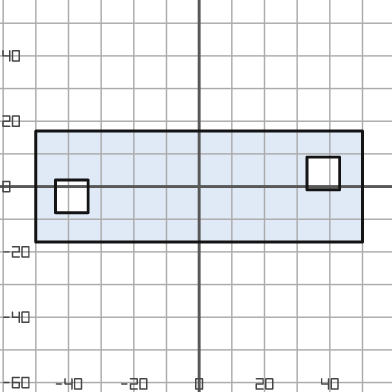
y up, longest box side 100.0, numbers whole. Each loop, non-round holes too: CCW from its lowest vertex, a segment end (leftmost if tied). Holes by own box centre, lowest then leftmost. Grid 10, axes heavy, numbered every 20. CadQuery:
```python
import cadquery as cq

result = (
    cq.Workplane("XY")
    .moveTo(-50.0, -17.0)
    .lineTo(50.0, -17.0)
    .lineTo(50.0, 17.0)
    .lineTo(-50.0, 17.0)
    .close()
    .moveTo(-44.0, -8.0)
    .lineTo(-34.0, -8.0)
    .lineTo(-34.0, 2.0)
    .lineTo(-44.0, 2.0)
    .close()
    .moveTo(33.0, -1.0)
    .lineTo(43.0, -1.0)
    .lineTo(43.0, 9.0)
    .lineTo(33.0, 9.0)
    .close()
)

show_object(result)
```